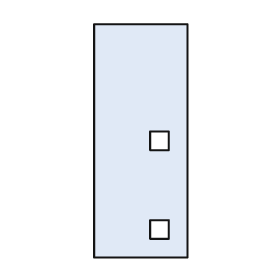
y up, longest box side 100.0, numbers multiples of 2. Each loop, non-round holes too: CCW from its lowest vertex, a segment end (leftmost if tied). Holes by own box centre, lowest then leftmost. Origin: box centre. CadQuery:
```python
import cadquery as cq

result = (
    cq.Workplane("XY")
    .moveTo(-20.0, -50.0)
    .lineTo(20.0, -50.0)
    .lineTo(20.0, 50.0)
    .lineTo(-20.0, 50.0)
    .close()
    .moveTo(4.0, -42.0)
    .lineTo(12.0, -42.0)
    .lineTo(12.0, -34.0)
    .lineTo(4.0, -34.0)
    .close()
    .moveTo(4.0, -4.0)
    .lineTo(12.0, -4.0)
    .lineTo(12.0, 4.0)
    .lineTo(4.0, 4.0)
    .close()
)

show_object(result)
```